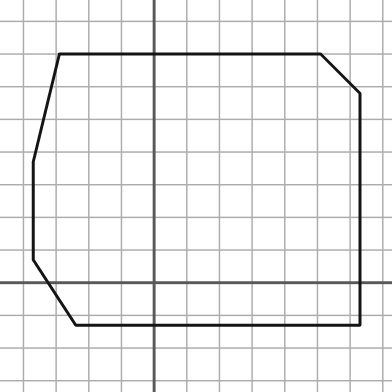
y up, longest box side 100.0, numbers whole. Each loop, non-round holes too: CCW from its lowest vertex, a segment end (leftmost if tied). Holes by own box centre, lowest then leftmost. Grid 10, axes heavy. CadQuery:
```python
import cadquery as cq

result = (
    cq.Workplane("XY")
    .moveTo(-24.0, -13.0)
    .lineTo(63.0, -13.0)
    .lineTo(63.0, 58.0)
    .lineTo(51.0, 70.0)
    .lineTo(-29.0, 70.0)
    .lineTo(-37.0, 37.0)
    .lineTo(-37.0, 7.0)
    .close()
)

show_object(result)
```